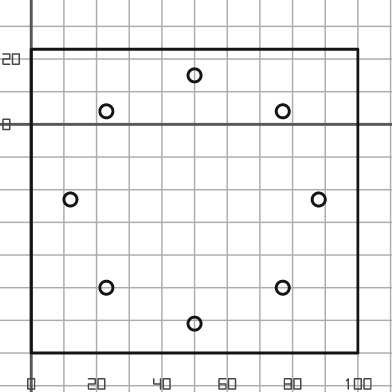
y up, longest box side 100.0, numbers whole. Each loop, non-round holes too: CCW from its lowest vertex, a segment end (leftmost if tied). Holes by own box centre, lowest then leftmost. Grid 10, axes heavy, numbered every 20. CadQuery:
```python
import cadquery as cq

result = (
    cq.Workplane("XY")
    .moveTo(0.0, -70.0)
    .lineTo(100.0, -70.0)
    .lineTo(100.0, 23.0)
    .lineTo(0.0, 23.0)
    .close()
    .moveTo(50.0, -61.0)
    .circle(2.0)
    .moveTo(23.0, -50.0)
    .circle(2.0)
    .moveTo(77.0, -50.0)
    .circle(2.0)
    .moveTo(12.0, -23.0)
    .circle(2.0)
    .moveTo(88.0, -23.0)
    .circle(2.0)
    .moveTo(23.0, 4.0)
    .circle(2.0)
    .moveTo(77.0, 4.0)
    .circle(2.0)
    .moveTo(50.0, 15.0)
    .circle(2.0)
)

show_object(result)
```